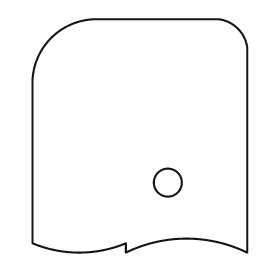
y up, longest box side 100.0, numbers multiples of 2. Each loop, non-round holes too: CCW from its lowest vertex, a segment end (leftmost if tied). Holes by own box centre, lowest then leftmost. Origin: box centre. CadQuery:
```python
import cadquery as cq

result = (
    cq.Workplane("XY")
    .moveTo(-6.0, -50.0)
    .threePointArc((20.0, -44.0), (46.0, -50.0))
    .lineTo(46.0, 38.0)
    .threePointArc((42.0, 46.0), (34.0, 50.0))
    .lineTo(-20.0, 50.0)
    .threePointArc((-38.0, 42.0), (-46.0, 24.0))
    .lineTo(-46.0, -46.0)
    .threePointArc((-26.0, -50.0), (-6.0, -46.0))
    .close()
    .moveTo(12.0, -20.0)
    .circle(6.0)
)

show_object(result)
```